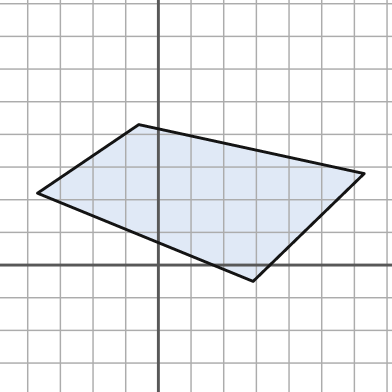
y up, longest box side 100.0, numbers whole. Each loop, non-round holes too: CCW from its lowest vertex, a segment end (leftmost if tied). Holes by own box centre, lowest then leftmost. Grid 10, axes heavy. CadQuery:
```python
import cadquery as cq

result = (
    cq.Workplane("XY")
    .moveTo(29.0, -5.0)
    .lineTo(63.0, 28.0)
    .lineTo(-6.0, 43.0)
    .lineTo(-37.0, 22.0)
    .close()
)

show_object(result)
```